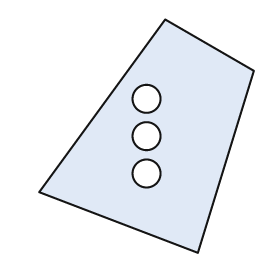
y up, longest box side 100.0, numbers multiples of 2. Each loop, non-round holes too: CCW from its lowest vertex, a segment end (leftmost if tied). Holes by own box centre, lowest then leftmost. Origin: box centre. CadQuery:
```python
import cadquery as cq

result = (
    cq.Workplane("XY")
    .moveTo(22.0, -50.0)
    .lineTo(46.0, 28.0)
    .lineTo(8.0, 50.0)
    .lineTo(-46.0, -24.0)
    .close()
    .moveTo(0.0, -16.0)
    .circle(6.0)
    .moveTo(0.0, 0.0)
    .circle(6.0)
    .moveTo(0.0, 16.0)
    .circle(6.0)
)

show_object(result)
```